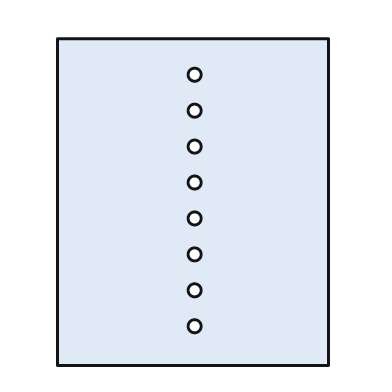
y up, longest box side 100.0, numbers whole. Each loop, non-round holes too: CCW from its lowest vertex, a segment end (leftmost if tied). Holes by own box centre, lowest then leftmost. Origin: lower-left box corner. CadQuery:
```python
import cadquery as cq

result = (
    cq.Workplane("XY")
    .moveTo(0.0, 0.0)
    .lineTo(83.0, 0.0)
    .lineTo(83.0, 100.0)
    .lineTo(0.0, 100.0)
    .close()
    .moveTo(42.0, 12.0)
    .circle(2.0)
    .moveTo(42.0, 23.0)
    .circle(2.0)
    .moveTo(42.0, 34.0)
    .circle(2.0)
    .moveTo(42.0, 45.0)
    .circle(2.0)
    .moveTo(42.0, 56.0)
    .circle(2.0)
    .moveTo(42.0, 67.0)
    .circle(2.0)
    .moveTo(42.0, 78.0)
    .circle(2.0)
    .moveTo(42.0, 89.0)
    .circle(2.0)
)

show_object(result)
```